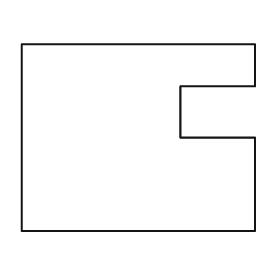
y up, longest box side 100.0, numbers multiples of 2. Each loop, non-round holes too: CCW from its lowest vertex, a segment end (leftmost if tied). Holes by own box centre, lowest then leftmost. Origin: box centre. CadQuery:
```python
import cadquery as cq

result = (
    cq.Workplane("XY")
    .moveTo(-50.0, -40.0)
    .lineTo(50.0, -40.0)
    .lineTo(50.0, 0.0)
    .lineTo(18.0, 0.0)
    .lineTo(18.0, 22.0)
    .lineTo(50.0, 22.0)
    .lineTo(50.0, 40.0)
    .lineTo(-50.0, 40.0)
    .close()
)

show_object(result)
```